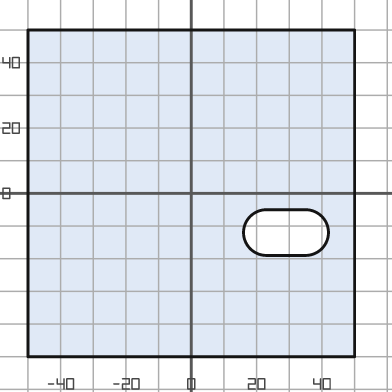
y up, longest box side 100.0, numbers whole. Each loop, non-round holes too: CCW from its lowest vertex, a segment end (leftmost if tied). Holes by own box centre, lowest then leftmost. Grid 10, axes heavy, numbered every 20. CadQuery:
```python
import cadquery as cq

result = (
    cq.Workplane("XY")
    .moveTo(-50.0, -50.0)
    .lineTo(50.0, -50.0)
    .lineTo(50.0, 50.0)
    .lineTo(-50.0, 50.0)
    .close()
    .moveTo(23.0, -19.0)
    .lineTo(35.0, -19.0)
    .threePointArc((42.0, -12.0), (35.0, -5.0))
    .lineTo(23.0, -5.0)
    .threePointArc((16.0, -12.0), (23.0, -19.0))
    .close()
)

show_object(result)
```